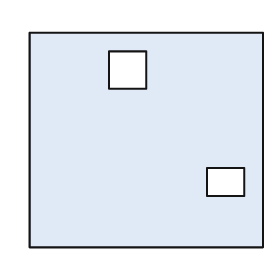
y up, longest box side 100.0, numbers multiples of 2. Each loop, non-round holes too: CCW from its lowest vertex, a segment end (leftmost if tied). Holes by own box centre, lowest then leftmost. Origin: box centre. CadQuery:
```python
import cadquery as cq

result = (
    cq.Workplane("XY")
    .moveTo(-50.0, -46.0)
    .lineTo(50.0, -46.0)
    .lineTo(50.0, 46.0)
    .lineTo(-50.0, 46.0)
    .close()
    .moveTo(26.0, -24.0)
    .lineTo(42.0, -24.0)
    .lineTo(42.0, -12.0)
    .lineTo(26.0, -12.0)
    .close()
    .moveTo(-16.0, 22.0)
    .lineTo(0.0, 22.0)
    .lineTo(0.0, 38.0)
    .lineTo(-16.0, 38.0)
    .close()
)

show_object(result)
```